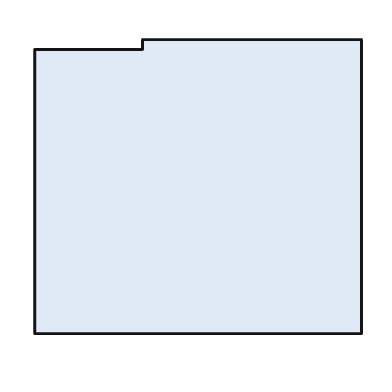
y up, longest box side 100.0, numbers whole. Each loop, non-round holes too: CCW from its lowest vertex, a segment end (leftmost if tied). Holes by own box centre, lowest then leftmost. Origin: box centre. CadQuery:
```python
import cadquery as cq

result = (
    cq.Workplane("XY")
    .moveTo(-50.0, -45.0)
    .lineTo(50.0, -45.0)
    .lineTo(50.0, 45.0)
    .lineTo(-17.0, 45.0)
    .lineTo(-17.0, 42.0)
    .lineTo(-50.0, 42.0)
    .close()
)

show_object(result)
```